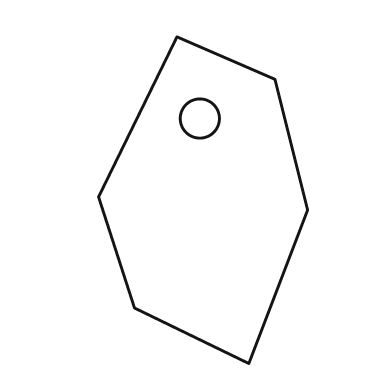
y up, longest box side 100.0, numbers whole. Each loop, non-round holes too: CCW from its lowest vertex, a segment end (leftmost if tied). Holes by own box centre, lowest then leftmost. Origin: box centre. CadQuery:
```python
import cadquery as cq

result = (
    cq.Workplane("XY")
    .moveTo(14.0, -50.0)
    .lineTo(32.0, -3.0)
    .lineTo(22.0, 37.0)
    .lineTo(-8.0, 50.0)
    .lineTo(-32.0, 1.0)
    .lineTo(-21.0, -33.0)
    .close()
    .moveTo(-1.0, 25.0)
    .circle(6.0)
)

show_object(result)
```